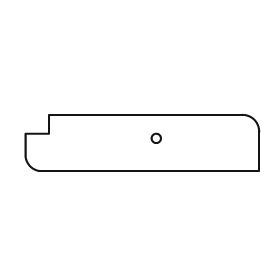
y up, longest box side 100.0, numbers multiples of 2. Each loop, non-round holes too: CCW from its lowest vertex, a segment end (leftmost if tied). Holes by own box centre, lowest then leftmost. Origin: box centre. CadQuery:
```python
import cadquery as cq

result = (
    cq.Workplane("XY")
    .moveTo(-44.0, -12.0)
    .lineTo(50.0, -12.0)
    .lineTo(50.0, 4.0)
    .threePointArc((48.0, 10.0), (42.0, 12.0))
    .lineTo(-40.0, 12.0)
    .lineTo(-40.0, 4.0)
    .lineTo(-50.0, 4.0)
    .lineTo(-50.0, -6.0)
    .threePointArc((-48.0, -10.0), (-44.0, -12.0))
    .close()
    .moveTo(6.0, 2.0)
    .circle(2.0)
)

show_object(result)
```